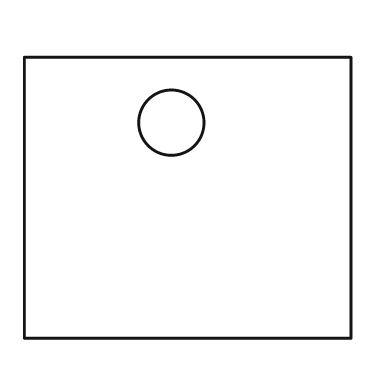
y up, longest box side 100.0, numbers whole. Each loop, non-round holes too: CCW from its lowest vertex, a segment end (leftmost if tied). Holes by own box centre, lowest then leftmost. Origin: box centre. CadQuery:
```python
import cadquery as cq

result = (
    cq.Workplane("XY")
    .moveTo(-50.0, -43.0)
    .lineTo(50.0, -43.0)
    .lineTo(50.0, 43.0)
    .lineTo(-50.0, 43.0)
    .close()
    .moveTo(-5.0, 23.0)
    .circle(10.0)
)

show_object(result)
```